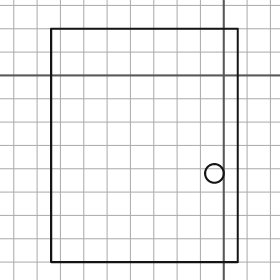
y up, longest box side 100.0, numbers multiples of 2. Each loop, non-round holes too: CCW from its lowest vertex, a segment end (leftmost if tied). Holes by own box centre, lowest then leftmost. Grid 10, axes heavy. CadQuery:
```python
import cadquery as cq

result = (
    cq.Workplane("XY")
    .moveTo(-74.0, -80.0)
    .lineTo(6.0, -80.0)
    .lineTo(6.0, 20.0)
    .lineTo(-74.0, 20.0)
    .close()
    .moveTo(-4.0, -42.0)
    .circle(4.0)
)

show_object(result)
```